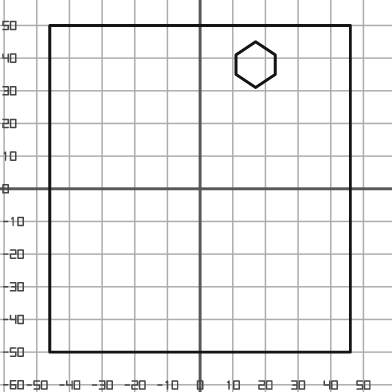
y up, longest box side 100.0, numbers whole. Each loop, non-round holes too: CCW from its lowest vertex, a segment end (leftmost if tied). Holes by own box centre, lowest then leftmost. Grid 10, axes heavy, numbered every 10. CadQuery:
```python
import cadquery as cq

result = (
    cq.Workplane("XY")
    .moveTo(-46.0, -50.0)
    .lineTo(46.0, -50.0)
    .lineTo(46.0, 50.0)
    .lineTo(-46.0, 50.0)
    .close()
    .moveTo(17.0, 31.0)
    .lineTo(23.0, 35.0)
    .lineTo(23.0, 41.0)
    .lineTo(17.0, 45.0)
    .lineTo(11.0, 41.0)
    .lineTo(11.0, 35.0)
    .close()
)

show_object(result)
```